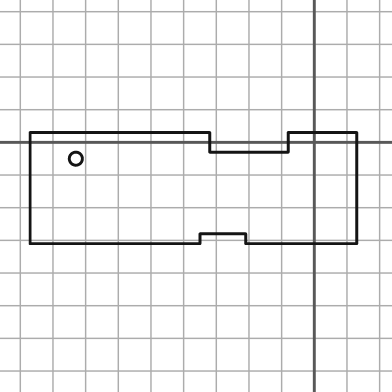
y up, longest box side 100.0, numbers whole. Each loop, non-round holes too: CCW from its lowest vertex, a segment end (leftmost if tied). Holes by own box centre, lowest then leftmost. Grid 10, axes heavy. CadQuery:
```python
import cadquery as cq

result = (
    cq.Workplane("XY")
    .moveTo(-87.0, -31.0)
    .lineTo(-35.0, -31.0)
    .lineTo(-35.0, -28.0)
    .lineTo(-21.0, -28.0)
    .lineTo(-21.0, -31.0)
    .lineTo(13.0, -31.0)
    .lineTo(13.0, 3.0)
    .lineTo(-8.0, 3.0)
    .lineTo(-8.0, -3.0)
    .lineTo(-32.0, -3.0)
    .lineTo(-32.0, 3.0)
    .lineTo(-87.0, 3.0)
    .close()
    .moveTo(-73.0, -5.0)
    .circle(2.0)
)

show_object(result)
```